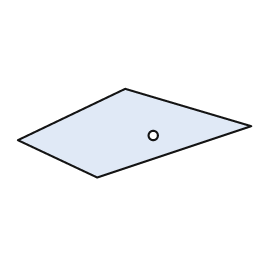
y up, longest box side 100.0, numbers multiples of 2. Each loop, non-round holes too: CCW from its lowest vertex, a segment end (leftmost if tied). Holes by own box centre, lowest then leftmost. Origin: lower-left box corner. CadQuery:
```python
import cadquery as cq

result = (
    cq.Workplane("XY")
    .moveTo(34.0, 0.0)
    .lineTo(100.0, 22.0)
    .lineTo(46.0, 38.0)
    .lineTo(0.0, 16.0)
    .close()
    .moveTo(58.0, 18.0)
    .circle(2.0)
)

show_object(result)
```